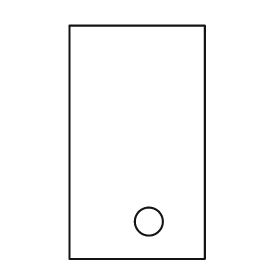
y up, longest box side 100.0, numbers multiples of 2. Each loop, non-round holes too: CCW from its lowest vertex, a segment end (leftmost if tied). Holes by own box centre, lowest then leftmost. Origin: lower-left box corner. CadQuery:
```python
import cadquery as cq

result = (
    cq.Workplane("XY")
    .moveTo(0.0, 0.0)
    .lineTo(58.0, 0.0)
    .lineTo(58.0, 100.0)
    .lineTo(0.0, 100.0)
    .close()
    .moveTo(34.0, 16.0)
    .circle(6.0)
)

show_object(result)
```